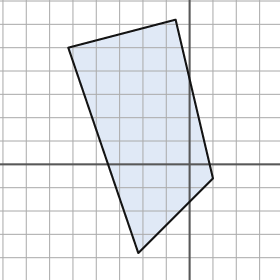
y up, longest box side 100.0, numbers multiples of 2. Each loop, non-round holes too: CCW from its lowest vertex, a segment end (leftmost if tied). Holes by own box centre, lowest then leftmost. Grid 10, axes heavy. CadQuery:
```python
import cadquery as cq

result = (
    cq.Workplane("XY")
    .moveTo(-22.0, -38.0)
    .lineTo(10.0, -6.0)
    .lineTo(-6.0, 62.0)
    .lineTo(-52.0, 50.0)
    .close()
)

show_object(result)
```